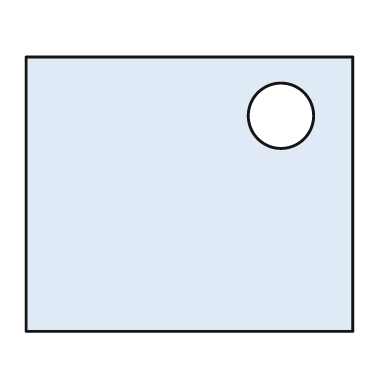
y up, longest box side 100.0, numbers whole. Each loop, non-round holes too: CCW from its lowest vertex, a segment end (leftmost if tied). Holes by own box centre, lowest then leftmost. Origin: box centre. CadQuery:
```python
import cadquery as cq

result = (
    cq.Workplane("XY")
    .moveTo(-50.0, -42.0)
    .lineTo(50.0, -42.0)
    .lineTo(50.0, 42.0)
    .lineTo(-50.0, 42.0)
    .close()
    .moveTo(28.0, 24.0)
    .circle(10.0)
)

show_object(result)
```